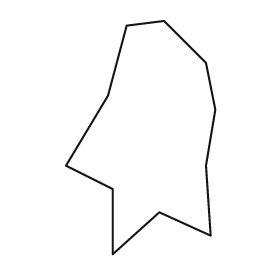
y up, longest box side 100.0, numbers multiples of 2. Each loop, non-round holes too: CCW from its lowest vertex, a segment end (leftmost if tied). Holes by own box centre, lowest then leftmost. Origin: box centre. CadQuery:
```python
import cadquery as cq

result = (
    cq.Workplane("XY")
    .moveTo(-12.0, -50.0)
    .lineTo(8.0, -32.0)
    .lineTo(30.0, -42.0)
    .lineTo(28.0, -12.0)
    .lineTo(32.0, 12.0)
    .lineTo(28.0, 32.0)
    .lineTo(10.0, 50.0)
    .lineTo(-6.0, 48.0)
    .lineTo(-14.0, 18.0)
    .lineTo(-32.0, -12.0)
    .lineTo(-12.0, -22.0)
    .close()
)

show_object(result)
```